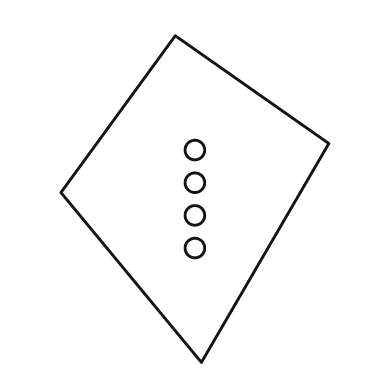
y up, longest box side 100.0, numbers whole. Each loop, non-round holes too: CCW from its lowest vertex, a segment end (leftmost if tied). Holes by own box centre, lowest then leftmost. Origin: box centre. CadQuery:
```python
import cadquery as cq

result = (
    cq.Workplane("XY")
    .moveTo(2.0, -50.0)
    .lineTo(41.0, 17.0)
    .lineTo(-6.0, 50.0)
    .lineTo(-41.0, 2.0)
    .close()
    .moveTo(0.0, -15.0)
    .circle(3.0)
    .moveTo(0.0, -5.0)
    .circle(3.0)
    .moveTo(0.0, 5.0)
    .circle(3.0)
    .moveTo(0.0, 15.0)
    .circle(3.0)
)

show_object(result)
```